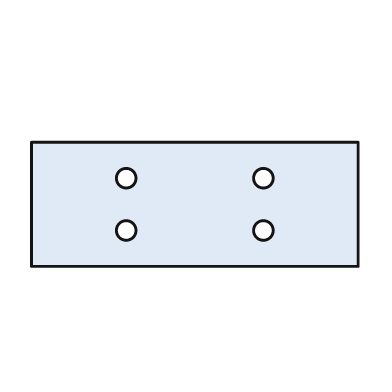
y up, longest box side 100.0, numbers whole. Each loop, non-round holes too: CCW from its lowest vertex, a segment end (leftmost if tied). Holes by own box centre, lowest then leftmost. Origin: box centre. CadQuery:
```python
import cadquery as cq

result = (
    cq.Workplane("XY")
    .moveTo(-50.0, -19.0)
    .lineTo(50.0, -19.0)
    .lineTo(50.0, 19.0)
    .lineTo(-50.0, 19.0)
    .close()
    .moveTo(-21.0, -8.0)
    .circle(3.0)
    .moveTo(21.0, -8.0)
    .circle(3.0)
    .moveTo(-21.0, 8.0)
    .circle(3.0)
    .moveTo(21.0, 8.0)
    .circle(3.0)
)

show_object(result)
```